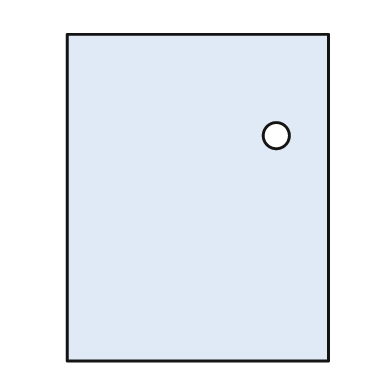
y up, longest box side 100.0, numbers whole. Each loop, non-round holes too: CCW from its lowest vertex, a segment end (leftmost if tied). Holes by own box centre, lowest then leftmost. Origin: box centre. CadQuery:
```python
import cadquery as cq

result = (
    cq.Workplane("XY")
    .moveTo(-40.0, -50.0)
    .lineTo(40.0, -50.0)
    .lineTo(40.0, 50.0)
    .lineTo(-40.0, 50.0)
    .close()
    .moveTo(24.0, 19.0)
    .circle(4.0)
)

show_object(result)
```